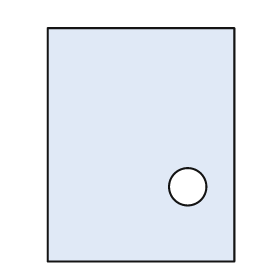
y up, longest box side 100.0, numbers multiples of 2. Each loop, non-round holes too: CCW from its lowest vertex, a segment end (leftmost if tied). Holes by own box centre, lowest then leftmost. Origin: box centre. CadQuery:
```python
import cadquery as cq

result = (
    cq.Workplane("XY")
    .moveTo(-40.0, -50.0)
    .lineTo(40.0, -50.0)
    .lineTo(40.0, 50.0)
    .lineTo(-40.0, 50.0)
    .close()
    .moveTo(20.0, -18.0)
    .circle(8.0)
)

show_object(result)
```